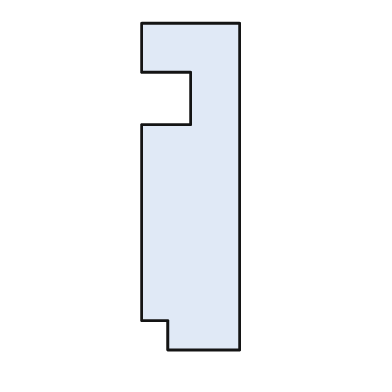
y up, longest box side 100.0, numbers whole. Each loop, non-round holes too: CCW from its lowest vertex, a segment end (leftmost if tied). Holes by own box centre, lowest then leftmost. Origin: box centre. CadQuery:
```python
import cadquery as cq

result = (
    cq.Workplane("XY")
    .moveTo(-7.0, -50.0)
    .lineTo(15.0, -50.0)
    .lineTo(15.0, 50.0)
    .lineTo(-15.0, 50.0)
    .lineTo(-15.0, 35.0)
    .lineTo(0.0, 35.0)
    .lineTo(0.0, 19.0)
    .lineTo(-15.0, 19.0)
    .lineTo(-15.0, -41.0)
    .lineTo(-7.0, -41.0)
    .close()
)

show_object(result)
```